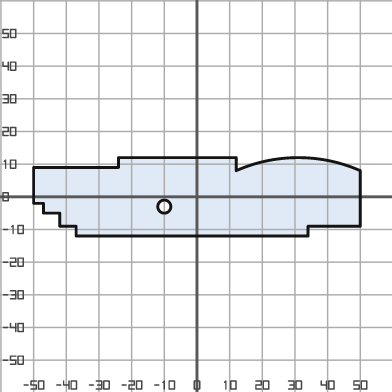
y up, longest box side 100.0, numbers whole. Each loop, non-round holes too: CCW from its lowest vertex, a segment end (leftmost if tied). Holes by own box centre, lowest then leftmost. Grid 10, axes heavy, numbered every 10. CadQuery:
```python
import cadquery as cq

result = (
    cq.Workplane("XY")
    .moveTo(-37.0, -12.0)
    .lineTo(34.0, -12.0)
    .lineTo(34.0, -9.0)
    .lineTo(50.0, -9.0)
    .lineTo(50.0, 8.0)
    .threePointArc((31.0, 12.0), (12.0, 8.0))
    .lineTo(12.0, 12.0)
    .lineTo(-24.0, 12.0)
    .lineTo(-24.0, 9.0)
    .lineTo(-50.0, 9.0)
    .lineTo(-50.0, -2.0)
    .lineTo(-47.0, -2.0)
    .lineTo(-47.0, -5.0)
    .lineTo(-42.0, -5.0)
    .lineTo(-42.0, -9.0)
    .lineTo(-37.0, -9.0)
    .close()
    .moveTo(-10.0, -3.0)
    .circle(2.0)
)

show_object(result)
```